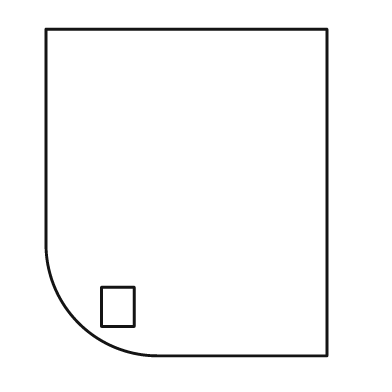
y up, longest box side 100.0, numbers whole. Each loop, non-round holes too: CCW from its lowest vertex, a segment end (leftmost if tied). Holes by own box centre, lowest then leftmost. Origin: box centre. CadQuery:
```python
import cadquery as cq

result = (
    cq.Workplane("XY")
    .moveTo(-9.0, -50.0)
    .lineTo(43.0, -50.0)
    .lineTo(43.0, 50.0)
    .lineTo(-43.0, 50.0)
    .lineTo(-43.0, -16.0)
    .threePointArc((-33.0, -40.0), (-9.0, -50.0))
    .close()
    .moveTo(-26.0, -41.0)
    .lineTo(-16.0, -41.0)
    .lineTo(-16.0, -29.0)
    .lineTo(-26.0, -29.0)
    .close()
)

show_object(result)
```